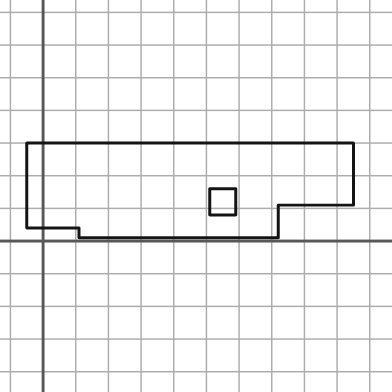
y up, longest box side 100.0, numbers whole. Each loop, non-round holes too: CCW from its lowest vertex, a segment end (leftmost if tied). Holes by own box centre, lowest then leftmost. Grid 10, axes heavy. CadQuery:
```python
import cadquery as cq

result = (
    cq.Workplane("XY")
    .moveTo(11.0, 1.0)
    .lineTo(72.0, 1.0)
    .lineTo(72.0, 11.0)
    .lineTo(95.0, 11.0)
    .lineTo(95.0, 30.0)
    .lineTo(-5.0, 30.0)
    .lineTo(-5.0, 4.0)
    .lineTo(11.0, 4.0)
    .close()
    .moveTo(51.0, 8.0)
    .lineTo(59.0, 8.0)
    .lineTo(59.0, 16.0)
    .lineTo(51.0, 16.0)
    .close()
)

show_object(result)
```